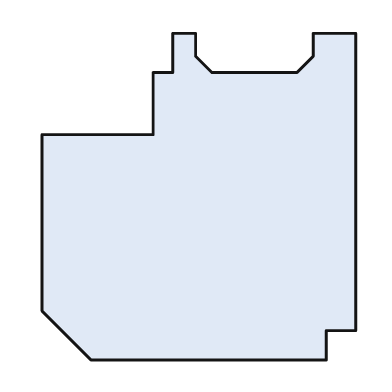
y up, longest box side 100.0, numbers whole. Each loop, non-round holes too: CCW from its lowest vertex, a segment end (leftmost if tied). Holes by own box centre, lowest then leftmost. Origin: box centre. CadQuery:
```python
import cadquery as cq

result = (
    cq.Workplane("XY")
    .moveTo(-33.0, -50.0)
    .lineTo(39.0, -50.0)
    .lineTo(39.0, -41.0)
    .lineTo(48.0, -41.0)
    .lineTo(48.0, 50.0)
    .lineTo(35.0, 50.0)
    .lineTo(35.0, 43.0)
    .lineTo(30.0, 38.0)
    .lineTo(4.0, 38.0)
    .lineTo(-1.0, 43.0)
    .lineTo(-1.0, 50.0)
    .lineTo(-8.0, 50.0)
    .lineTo(-8.0, 38.0)
    .lineTo(-14.0, 38.0)
    .lineTo(-14.0, 19.0)
    .lineTo(-48.0, 19.0)
    .lineTo(-48.0, -35.0)
    .close()
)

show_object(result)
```